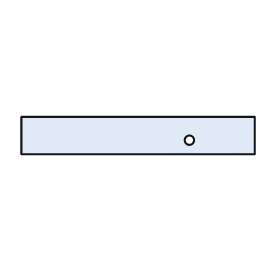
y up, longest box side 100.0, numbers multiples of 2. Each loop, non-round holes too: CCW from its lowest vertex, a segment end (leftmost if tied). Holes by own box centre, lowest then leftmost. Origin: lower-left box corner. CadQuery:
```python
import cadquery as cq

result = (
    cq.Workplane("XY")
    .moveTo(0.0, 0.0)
    .lineTo(100.0, 0.0)
    .lineTo(100.0, 16.0)
    .lineTo(0.0, 16.0)
    .close()
    .moveTo(72.0, 6.0)
    .circle(2.0)
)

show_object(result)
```